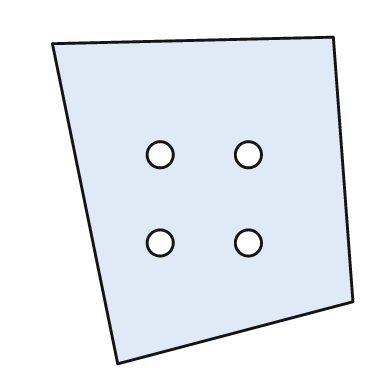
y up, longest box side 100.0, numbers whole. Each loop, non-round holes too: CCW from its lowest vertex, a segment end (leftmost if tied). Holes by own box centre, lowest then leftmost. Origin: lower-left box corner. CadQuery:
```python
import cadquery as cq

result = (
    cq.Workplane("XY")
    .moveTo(20.0, 0.0)
    .lineTo(92.0, 19.0)
    .lineTo(86.0, 100.0)
    .lineTo(0.0, 98.0)
    .close()
    .moveTo(33.0, 37.0)
    .circle(4.0)
    .moveTo(60.0, 37.0)
    .circle(4.0)
    .moveTo(33.0, 64.0)
    .circle(4.0)
    .moveTo(60.0, 64.0)
    .circle(4.0)
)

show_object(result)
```